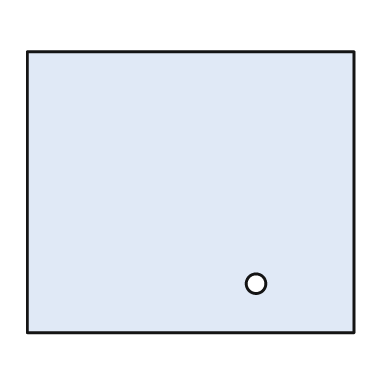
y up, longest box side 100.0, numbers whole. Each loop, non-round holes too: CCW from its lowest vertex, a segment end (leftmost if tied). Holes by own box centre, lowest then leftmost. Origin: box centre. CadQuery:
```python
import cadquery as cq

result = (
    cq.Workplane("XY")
    .moveTo(-50.0, -43.0)
    .lineTo(50.0, -43.0)
    .lineTo(50.0, 43.0)
    .lineTo(-50.0, 43.0)
    .close()
    .moveTo(20.0, -28.0)
    .circle(3.0)
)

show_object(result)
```